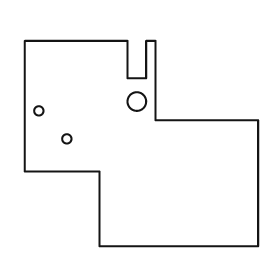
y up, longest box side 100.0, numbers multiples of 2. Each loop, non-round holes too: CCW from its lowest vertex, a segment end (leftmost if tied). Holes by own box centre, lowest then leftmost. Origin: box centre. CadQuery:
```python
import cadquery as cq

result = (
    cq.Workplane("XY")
    .moveTo(-18.0, -44.0)
    .lineTo(50.0, -44.0)
    .lineTo(50.0, 10.0)
    .lineTo(6.0, 10.0)
    .lineTo(6.0, 44.0)
    .lineTo(2.0, 44.0)
    .lineTo(2.0, 28.0)
    .lineTo(-6.0, 28.0)
    .lineTo(-6.0, 44.0)
    .lineTo(-50.0, 44.0)
    .lineTo(-50.0, -12.0)
    .lineTo(-18.0, -12.0)
    .close()
    .moveTo(-32.0, 2.0)
    .circle(2.0)
    .moveTo(-44.0, 14.0)
    .circle(2.0)
    .moveTo(-2.0, 18.0)
    .circle(4.0)
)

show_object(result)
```